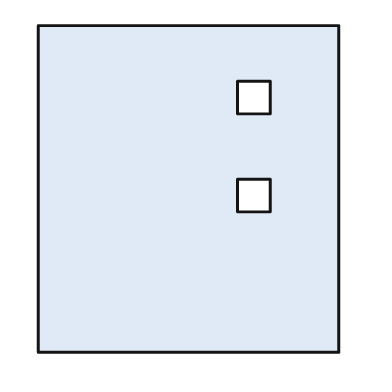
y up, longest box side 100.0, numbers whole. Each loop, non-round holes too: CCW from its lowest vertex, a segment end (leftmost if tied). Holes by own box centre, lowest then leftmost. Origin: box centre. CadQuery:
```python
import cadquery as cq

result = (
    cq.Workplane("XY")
    .moveTo(-46.0, -50.0)
    .lineTo(46.0, -50.0)
    .lineTo(46.0, 50.0)
    .lineTo(-46.0, 50.0)
    .close()
    .moveTo(15.0, -7.0)
    .lineTo(25.0, -7.0)
    .lineTo(25.0, 3.0)
    .lineTo(15.0, 3.0)
    .close()
    .moveTo(15.0, 23.0)
    .lineTo(25.0, 23.0)
    .lineTo(25.0, 33.0)
    .lineTo(15.0, 33.0)
    .close()
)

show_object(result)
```